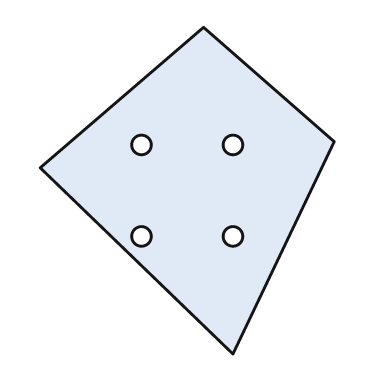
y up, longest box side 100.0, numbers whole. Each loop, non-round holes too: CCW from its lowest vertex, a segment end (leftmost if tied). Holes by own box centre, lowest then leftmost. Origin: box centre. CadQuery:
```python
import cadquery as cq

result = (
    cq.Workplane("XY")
    .moveTo(14.0, -50.0)
    .lineTo(45.0, 15.0)
    .lineTo(5.0, 50.0)
    .lineTo(-45.0, 7.0)
    .close()
    .moveTo(-14.0, -14.0)
    .circle(3.0)
    .moveTo(14.0, -14.0)
    .circle(3.0)
    .moveTo(-14.0, 14.0)
    .circle(3.0)
    .moveTo(14.0, 14.0)
    .circle(3.0)
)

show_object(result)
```